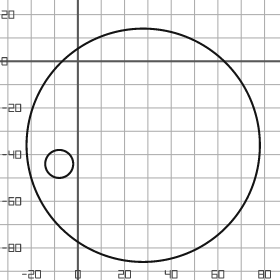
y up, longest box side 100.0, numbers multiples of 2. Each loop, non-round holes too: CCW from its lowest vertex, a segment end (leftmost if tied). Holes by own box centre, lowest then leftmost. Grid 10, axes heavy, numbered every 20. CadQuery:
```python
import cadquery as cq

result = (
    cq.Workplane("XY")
    .moveTo(28.0, -36.0)
    .circle(50.0)
    .moveTo(-8.0, -44.0)
    .circle(6.0)
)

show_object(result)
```